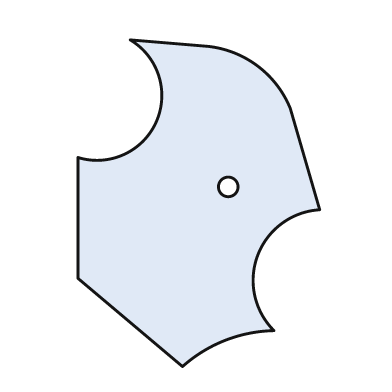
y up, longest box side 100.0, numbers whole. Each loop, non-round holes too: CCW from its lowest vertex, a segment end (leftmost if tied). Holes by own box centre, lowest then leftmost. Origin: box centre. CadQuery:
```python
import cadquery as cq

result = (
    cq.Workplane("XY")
    .moveTo(-5.0, -50.0)
    .threePointArc((8.0, -42.0), (23.0, -39.0))
    .threePointArc((18.0, -16.0), (37.0, -2.0))
    .lineTo(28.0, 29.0)
    .threePointArc((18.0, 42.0), (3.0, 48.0))
    .lineTo(-21.0, 50.0)
    .threePointArc((-13.0, 25.0), (-37.0, 14.0))
    .lineTo(-37.0, -23.0)
    .close()
    .moveTo(9.0, 5.0)
    .circle(3.0)
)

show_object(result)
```